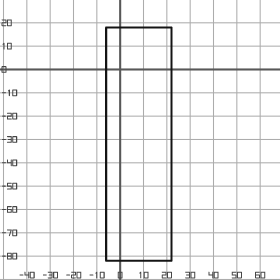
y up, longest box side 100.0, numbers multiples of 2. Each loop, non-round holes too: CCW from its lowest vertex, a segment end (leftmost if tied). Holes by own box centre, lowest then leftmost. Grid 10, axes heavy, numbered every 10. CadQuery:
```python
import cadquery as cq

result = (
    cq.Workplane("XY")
    .moveTo(-6.0, -82.0)
    .lineTo(22.0, -82.0)
    .lineTo(22.0, 18.0)
    .lineTo(-6.0, 18.0)
    .close()
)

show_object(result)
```